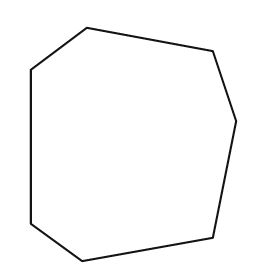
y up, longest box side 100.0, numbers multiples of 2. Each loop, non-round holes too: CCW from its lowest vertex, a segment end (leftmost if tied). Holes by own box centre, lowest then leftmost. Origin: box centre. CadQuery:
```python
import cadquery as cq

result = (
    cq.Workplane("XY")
    .moveTo(-22.0, -50.0)
    .lineTo(34.0, -40.0)
    .lineTo(44.0, 10.0)
    .lineTo(34.0, 40.0)
    .lineTo(-20.0, 50.0)
    .lineTo(-44.0, 32.0)
    .lineTo(-44.0, -34.0)
    .close()
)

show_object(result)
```